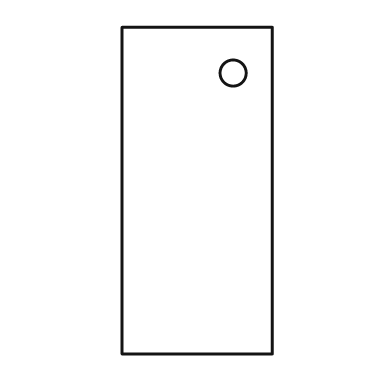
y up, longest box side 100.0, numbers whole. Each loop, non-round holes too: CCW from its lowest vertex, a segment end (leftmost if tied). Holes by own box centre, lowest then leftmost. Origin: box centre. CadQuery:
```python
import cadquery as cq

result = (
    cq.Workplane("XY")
    .moveTo(-23.0, -50.0)
    .lineTo(23.0, -50.0)
    .lineTo(23.0, 50.0)
    .lineTo(-23.0, 50.0)
    .close()
    .moveTo(11.0, 36.0)
    .circle(4.0)
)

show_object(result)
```